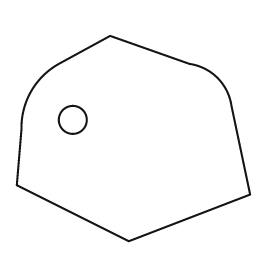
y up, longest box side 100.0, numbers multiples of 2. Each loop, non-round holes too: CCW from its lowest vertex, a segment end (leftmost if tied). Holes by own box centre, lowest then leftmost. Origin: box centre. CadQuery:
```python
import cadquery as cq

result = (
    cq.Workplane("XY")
    .moveTo(-2.0, -44.0)
    .lineTo(50.0, -24.0)
    .lineTo(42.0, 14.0)
    .threePointArc((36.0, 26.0), (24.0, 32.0))
    .lineTo(-10.0, 44.0)
    .lineTo(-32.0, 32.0)
    .threePointArc((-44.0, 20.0), (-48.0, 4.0))
    .lineTo(-50.0, -20.0)
    .close()
    .moveTo(-26.0, 8.0)
    .circle(6.0)
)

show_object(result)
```